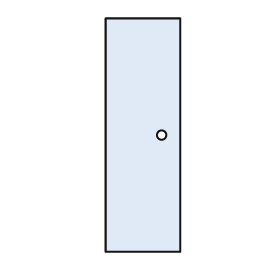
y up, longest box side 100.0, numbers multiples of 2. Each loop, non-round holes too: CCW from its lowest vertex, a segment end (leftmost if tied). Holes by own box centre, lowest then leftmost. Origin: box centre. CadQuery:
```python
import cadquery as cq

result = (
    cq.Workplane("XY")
    .moveTo(-16.0, -50.0)
    .lineTo(16.0, -50.0)
    .lineTo(16.0, 50.0)
    .lineTo(-16.0, 50.0)
    .close()
    .moveTo(8.0, 0.0)
    .circle(2.0)
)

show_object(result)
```